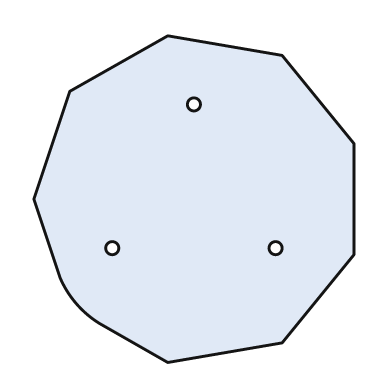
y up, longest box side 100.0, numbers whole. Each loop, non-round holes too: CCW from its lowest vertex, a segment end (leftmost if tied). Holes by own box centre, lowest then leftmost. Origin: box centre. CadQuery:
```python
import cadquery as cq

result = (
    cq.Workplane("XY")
    .moveTo(-8.0, -50.0)
    .lineTo(27.0, -44.0)
    .lineTo(49.0, -17.0)
    .lineTo(49.0, 17.0)
    .lineTo(27.0, 44.0)
    .lineTo(-8.0, 50.0)
    .lineTo(-38.0, 33.0)
    .lineTo(-49.0, 0.0)
    .lineTo(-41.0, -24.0)
    .threePointArc((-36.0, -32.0), (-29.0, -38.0))
    .close()
    .moveTo(-25.0, -15.0)
    .circle(2.0)
    .moveTo(25.0, -15.0)
    .circle(2.0)
    .moveTo(0.0, 29.0)
    .circle(2.0)
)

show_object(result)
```